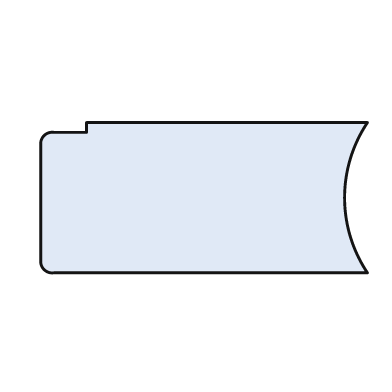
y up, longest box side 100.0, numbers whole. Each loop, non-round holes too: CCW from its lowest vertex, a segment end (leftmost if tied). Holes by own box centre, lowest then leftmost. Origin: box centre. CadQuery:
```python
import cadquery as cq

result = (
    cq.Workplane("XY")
    .moveTo(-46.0, -23.0)
    .lineTo(50.0, -23.0)
    .threePointArc((43.0, 0.0), (50.0, 23.0))
    .lineTo(-36.0, 23.0)
    .lineTo(-36.0, 20.0)
    .lineTo(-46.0, 20.0)
    .threePointArc((-49.0, 19.0), (-50.0, 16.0))
    .lineTo(-50.0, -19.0)
    .threePointArc((-49.0, -22.0), (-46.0, -23.0))
    .close()
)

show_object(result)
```